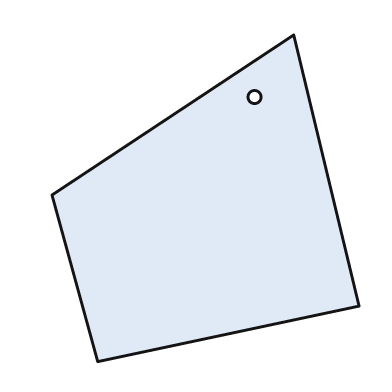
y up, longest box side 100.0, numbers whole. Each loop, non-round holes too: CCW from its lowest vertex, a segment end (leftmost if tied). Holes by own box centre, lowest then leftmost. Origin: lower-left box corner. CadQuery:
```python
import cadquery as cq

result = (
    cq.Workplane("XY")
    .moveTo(14.0, 0.0)
    .lineTo(94.0, 17.0)
    .lineTo(74.0, 100.0)
    .lineTo(0.0, 51.0)
    .close()
    .moveTo(62.0, 81.0)
    .circle(2.0)
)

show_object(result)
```